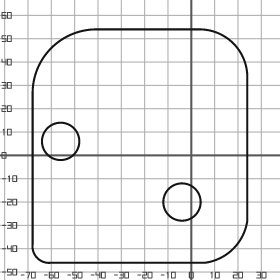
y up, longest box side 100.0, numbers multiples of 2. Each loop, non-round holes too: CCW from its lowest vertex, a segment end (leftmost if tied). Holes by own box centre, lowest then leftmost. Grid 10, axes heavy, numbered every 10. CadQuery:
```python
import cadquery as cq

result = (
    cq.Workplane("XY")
    .moveTo(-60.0, -46.0)
    .lineTo(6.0, -46.0)
    .threePointArc((18.0, -40.0), (24.0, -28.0))
    .lineTo(24.0, 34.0)
    .threePointArc((18.0, 48.0), (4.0, 54.0))
    .lineTo(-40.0, 54.0)
    .threePointArc((-60.0, 46.0), (-68.0, 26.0))
    .lineTo(-68.0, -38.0)
    .threePointArc((-66.0, -44.0), (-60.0, -46.0))
    .close()
    .moveTo(-4.0, -20.0)
    .circle(8.0)
    .moveTo(-56.0, 6.0)
    .circle(8.0)
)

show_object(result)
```